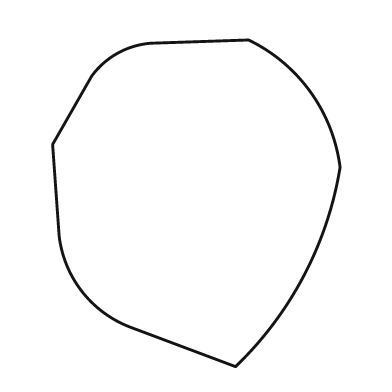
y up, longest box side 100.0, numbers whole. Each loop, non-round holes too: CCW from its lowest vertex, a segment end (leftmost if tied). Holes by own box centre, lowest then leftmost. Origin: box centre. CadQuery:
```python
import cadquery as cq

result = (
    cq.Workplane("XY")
    .moveTo(12.0, -50.0)
    .threePointArc((33.0, -22.0), (44.0, 11.0))
    .threePointArc((35.0, 34.0), (16.0, 50.0))
    .lineTo(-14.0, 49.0)
    .threePointArc((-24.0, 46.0), (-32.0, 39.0))
    .lineTo(-44.0, 18.0)
    .lineTo(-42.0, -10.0)
    .threePointArc((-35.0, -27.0), (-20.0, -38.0))
    .close()
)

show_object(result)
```